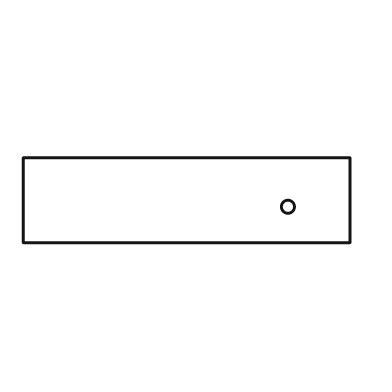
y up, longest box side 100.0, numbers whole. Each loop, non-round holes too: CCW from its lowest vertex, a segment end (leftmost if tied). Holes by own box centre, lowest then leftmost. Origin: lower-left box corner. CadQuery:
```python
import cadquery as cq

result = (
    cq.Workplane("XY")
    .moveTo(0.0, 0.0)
    .lineTo(100.0, 0.0)
    .lineTo(100.0, 26.0)
    .lineTo(0.0, 26.0)
    .close()
    .moveTo(81.0, 11.0)
    .circle(2.0)
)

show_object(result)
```